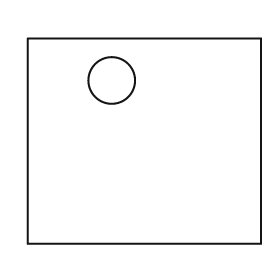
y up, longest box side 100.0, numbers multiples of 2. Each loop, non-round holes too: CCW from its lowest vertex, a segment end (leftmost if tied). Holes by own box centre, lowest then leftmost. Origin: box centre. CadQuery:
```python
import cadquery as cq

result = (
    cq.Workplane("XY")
    .moveTo(-50.0, -44.0)
    .lineTo(50.0, -44.0)
    .lineTo(50.0, 44.0)
    .lineTo(-50.0, 44.0)
    .close()
    .moveTo(-14.0, 26.0)
    .circle(10.0)
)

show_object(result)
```